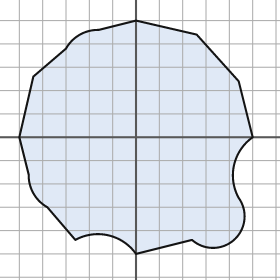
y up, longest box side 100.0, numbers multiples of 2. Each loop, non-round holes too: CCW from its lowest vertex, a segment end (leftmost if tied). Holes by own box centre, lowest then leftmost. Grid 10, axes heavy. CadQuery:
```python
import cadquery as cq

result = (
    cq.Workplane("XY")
    .moveTo(0.0, -50.0)
    .lineTo(24.0, -44.0)
    .threePointArc((42.0, -44.0), (44.0, -26.0))
    .threePointArc((42.0, -12.0), (50.0, 0.0))
    .lineTo(44.0, 24.0)
    .lineTo(26.0, 44.0)
    .lineTo(0.0, 50.0)
    .lineTo(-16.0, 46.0)
    .threePointArc((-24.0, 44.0), (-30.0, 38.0))
    .lineTo(-44.0, 26.0)
    .lineTo(-50.0, 0.0)
    .lineTo(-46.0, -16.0)
    .threePointArc((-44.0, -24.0), (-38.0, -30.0))
    .lineTo(-26.0, -44.0)
    .threePointArc((-12.0, -42.0), (0.0, -50.0))
    .close()
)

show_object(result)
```